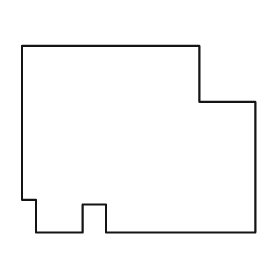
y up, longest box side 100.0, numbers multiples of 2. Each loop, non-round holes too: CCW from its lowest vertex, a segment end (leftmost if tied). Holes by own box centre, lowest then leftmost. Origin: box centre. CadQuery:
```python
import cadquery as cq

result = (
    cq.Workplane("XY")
    .moveTo(-44.0, -40.0)
    .lineTo(-24.0, -40.0)
    .lineTo(-24.0, -28.0)
    .lineTo(-14.0, -28.0)
    .lineTo(-14.0, -40.0)
    .lineTo(50.0, -40.0)
    .lineTo(50.0, 16.0)
    .lineTo(26.0, 16.0)
    .lineTo(26.0, 40.0)
    .lineTo(-50.0, 40.0)
    .lineTo(-50.0, -26.0)
    .lineTo(-44.0, -26.0)
    .close()
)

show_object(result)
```